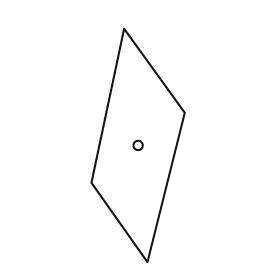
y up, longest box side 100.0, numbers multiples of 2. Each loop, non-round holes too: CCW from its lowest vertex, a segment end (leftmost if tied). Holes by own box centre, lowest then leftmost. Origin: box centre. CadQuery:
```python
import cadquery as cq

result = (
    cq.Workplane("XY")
    .moveTo(4.0, -50.0)
    .lineTo(20.0, 14.0)
    .lineTo(-6.0, 50.0)
    .lineTo(-20.0, -16.0)
    .close()
    .moveTo(0.0, 0.0)
    .circle(2.0)
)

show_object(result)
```